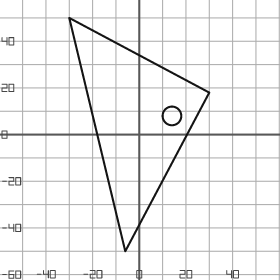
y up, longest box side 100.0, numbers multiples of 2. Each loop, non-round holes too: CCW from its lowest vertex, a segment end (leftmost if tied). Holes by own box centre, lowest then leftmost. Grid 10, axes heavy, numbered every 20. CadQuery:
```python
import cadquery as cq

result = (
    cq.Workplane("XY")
    .moveTo(-6.0, -50.0)
    .lineTo(30.0, 18.0)
    .lineTo(-30.0, 50.0)
    .close()
    .moveTo(14.0, 8.0)
    .circle(4.0)
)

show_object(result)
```